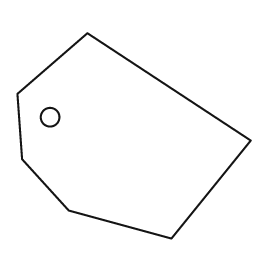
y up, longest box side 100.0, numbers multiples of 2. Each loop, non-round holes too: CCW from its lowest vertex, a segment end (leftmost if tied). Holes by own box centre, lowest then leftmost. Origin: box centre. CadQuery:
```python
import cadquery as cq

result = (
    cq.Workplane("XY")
    .moveTo(16.0, -44.0)
    .lineTo(50.0, -2.0)
    .lineTo(-20.0, 44.0)
    .lineTo(-50.0, 18.0)
    .lineTo(-48.0, -10.0)
    .lineTo(-28.0, -32.0)
    .close()
    .moveTo(-36.0, 8.0)
    .circle(4.0)
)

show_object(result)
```